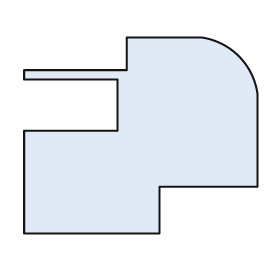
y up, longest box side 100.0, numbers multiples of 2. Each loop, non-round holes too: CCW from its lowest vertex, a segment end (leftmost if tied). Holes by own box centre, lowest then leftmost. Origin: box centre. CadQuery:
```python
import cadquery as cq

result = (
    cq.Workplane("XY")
    .moveTo(-50.0, -42.0)
    .lineTo(8.0, -42.0)
    .lineTo(8.0, -22.0)
    .lineTo(50.0, -22.0)
    .lineTo(50.0, 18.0)
    .threePointArc((42.0, 34.0), (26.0, 42.0))
    .lineTo(-6.0, 42.0)
    .lineTo(-6.0, 28.0)
    .lineTo(-50.0, 28.0)
    .lineTo(-50.0, 24.0)
    .lineTo(-10.0, 24.0)
    .lineTo(-10.0, 2.0)
    .lineTo(-50.0, 2.0)
    .close()
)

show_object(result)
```